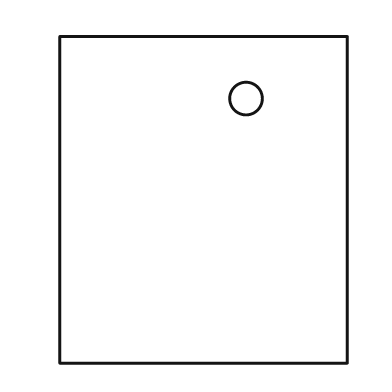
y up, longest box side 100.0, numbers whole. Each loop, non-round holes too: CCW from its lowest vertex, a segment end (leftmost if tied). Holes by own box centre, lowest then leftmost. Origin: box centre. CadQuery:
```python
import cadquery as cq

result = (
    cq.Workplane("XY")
    .moveTo(-44.0, -50.0)
    .lineTo(44.0, -50.0)
    .lineTo(44.0, 50.0)
    .lineTo(-44.0, 50.0)
    .close()
    .moveTo(13.0, 31.0)
    .circle(5.0)
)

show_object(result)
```